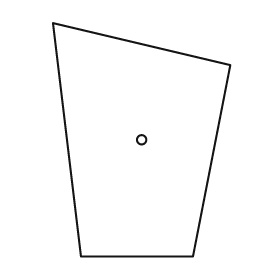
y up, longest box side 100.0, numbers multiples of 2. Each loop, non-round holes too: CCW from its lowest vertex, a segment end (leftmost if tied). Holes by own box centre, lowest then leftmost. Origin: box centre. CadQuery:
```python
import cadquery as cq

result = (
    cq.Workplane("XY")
    .moveTo(-26.0, -50.0)
    .lineTo(22.0, -50.0)
    .lineTo(38.0, 32.0)
    .lineTo(-38.0, 50.0)
    .close()
    .moveTo(0.0, 0.0)
    .circle(2.0)
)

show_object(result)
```